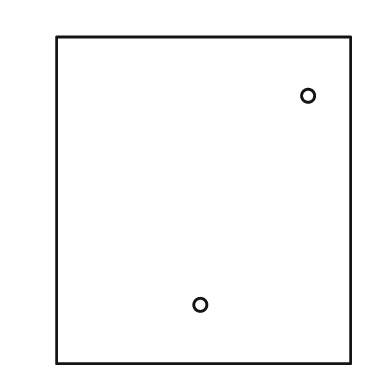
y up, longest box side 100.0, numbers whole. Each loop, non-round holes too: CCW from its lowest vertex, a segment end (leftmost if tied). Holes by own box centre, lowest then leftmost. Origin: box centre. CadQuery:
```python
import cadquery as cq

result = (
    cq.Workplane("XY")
    .moveTo(-45.0, -50.0)
    .lineTo(45.0, -50.0)
    .lineTo(45.0, 50.0)
    .lineTo(-45.0, 50.0)
    .close()
    .moveTo(-1.0, -32.0)
    .circle(2.0)
    .moveTo(32.0, 32.0)
    .circle(2.0)
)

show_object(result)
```